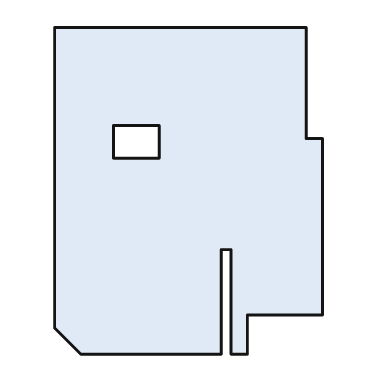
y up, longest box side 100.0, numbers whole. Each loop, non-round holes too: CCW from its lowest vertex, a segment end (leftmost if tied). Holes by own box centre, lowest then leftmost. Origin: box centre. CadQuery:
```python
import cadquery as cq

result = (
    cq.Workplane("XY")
    .moveTo(-33.0, -50.0)
    .lineTo(10.0, -50.0)
    .lineTo(10.0, -18.0)
    .lineTo(13.0, -18.0)
    .lineTo(13.0, -50.0)
    .lineTo(18.0, -50.0)
    .lineTo(18.0, -38.0)
    .lineTo(41.0, -38.0)
    .lineTo(41.0, 16.0)
    .lineTo(36.0, 16.0)
    .lineTo(36.0, 50.0)
    .lineTo(-41.0, 50.0)
    .lineTo(-41.0, -42.0)
    .close()
    .moveTo(-23.0, 10.0)
    .lineTo(-9.0, 10.0)
    .lineTo(-9.0, 20.0)
    .lineTo(-23.0, 20.0)
    .close()
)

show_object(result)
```